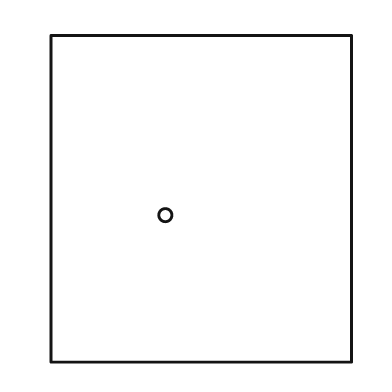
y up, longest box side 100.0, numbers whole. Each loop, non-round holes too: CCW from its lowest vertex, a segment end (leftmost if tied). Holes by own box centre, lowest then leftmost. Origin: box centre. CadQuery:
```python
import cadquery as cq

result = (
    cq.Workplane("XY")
    .moveTo(-46.0, -50.0)
    .lineTo(46.0, -50.0)
    .lineTo(46.0, 50.0)
    .lineTo(-46.0, 50.0)
    .close()
    .moveTo(-11.0, -5.0)
    .circle(2.0)
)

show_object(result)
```